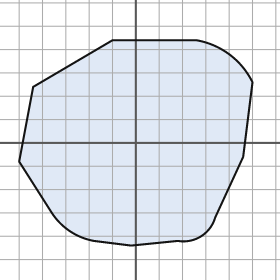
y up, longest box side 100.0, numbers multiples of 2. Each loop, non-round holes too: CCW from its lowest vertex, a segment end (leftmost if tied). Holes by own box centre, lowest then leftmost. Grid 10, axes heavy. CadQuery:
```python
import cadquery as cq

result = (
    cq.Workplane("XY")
    .moveTo(-2.0, -44.0)
    .lineTo(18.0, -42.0)
    .threePointArc((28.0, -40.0), (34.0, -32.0))
    .lineTo(46.0, -6.0)
    .lineTo(50.0, 26.0)
    .threePointArc((40.0, 38.0), (26.0, 44.0))
    .lineTo(-10.0, 44.0)
    .lineTo(-44.0, 24.0)
    .lineTo(-50.0, -8.0)
    .lineTo(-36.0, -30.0)
    .threePointArc((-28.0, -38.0), (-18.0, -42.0))
    .close()
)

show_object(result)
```